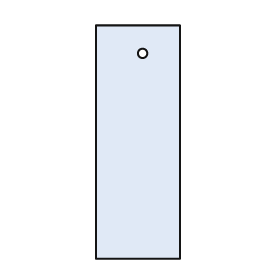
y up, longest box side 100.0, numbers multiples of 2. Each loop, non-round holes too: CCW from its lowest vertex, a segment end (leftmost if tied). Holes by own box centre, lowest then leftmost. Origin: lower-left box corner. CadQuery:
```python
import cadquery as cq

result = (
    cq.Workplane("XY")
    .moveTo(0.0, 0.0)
    .lineTo(36.0, 0.0)
    .lineTo(36.0, 100.0)
    .lineTo(0.0, 100.0)
    .close()
    .moveTo(20.0, 88.0)
    .circle(2.0)
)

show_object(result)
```